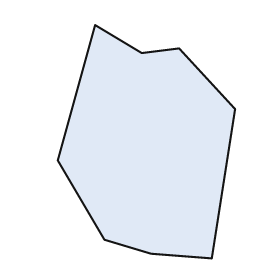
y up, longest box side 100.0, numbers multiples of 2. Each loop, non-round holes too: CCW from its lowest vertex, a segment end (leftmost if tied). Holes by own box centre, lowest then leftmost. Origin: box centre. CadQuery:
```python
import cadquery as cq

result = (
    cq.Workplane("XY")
    .moveTo(28.0, -50.0)
    .lineTo(38.0, 14.0)
    .lineTo(14.0, 40.0)
    .lineTo(-2.0, 38.0)
    .lineTo(-22.0, 50.0)
    .lineTo(-38.0, -8.0)
    .lineTo(-18.0, -42.0)
    .lineTo(2.0, -48.0)
    .close()
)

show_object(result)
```